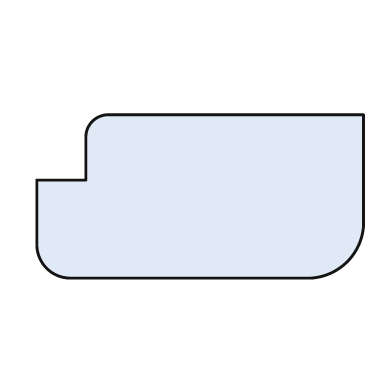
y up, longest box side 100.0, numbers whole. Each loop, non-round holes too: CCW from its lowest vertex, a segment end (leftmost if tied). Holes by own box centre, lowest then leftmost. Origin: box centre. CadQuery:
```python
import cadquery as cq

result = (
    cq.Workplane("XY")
    .moveTo(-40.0, -25.0)
    .lineTo(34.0, -25.0)
    .threePointArc((45.0, -20.0), (50.0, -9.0))
    .lineTo(50.0, 25.0)
    .lineTo(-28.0, 25.0)
    .threePointArc((-33.0, 23.0), (-35.0, 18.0))
    .lineTo(-35.0, 5.0)
    .lineTo(-50.0, 5.0)
    .lineTo(-50.0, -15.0)
    .threePointArc((-47.0, -22.0), (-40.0, -25.0))
    .close()
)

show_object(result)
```